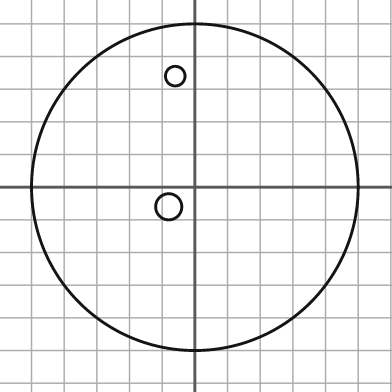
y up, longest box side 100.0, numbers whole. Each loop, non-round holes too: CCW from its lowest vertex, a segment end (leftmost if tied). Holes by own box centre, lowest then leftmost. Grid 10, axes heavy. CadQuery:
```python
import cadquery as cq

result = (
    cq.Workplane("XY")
    .moveTo(0.0, 0.0)
    .circle(50.0)
    .moveTo(-8.0, -6.0)
    .circle(4.0)
    .moveTo(-6.0, 34.0)
    .circle(3.0)
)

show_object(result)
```